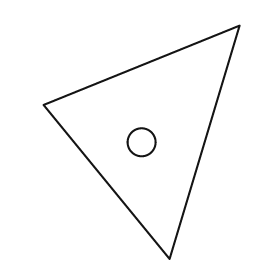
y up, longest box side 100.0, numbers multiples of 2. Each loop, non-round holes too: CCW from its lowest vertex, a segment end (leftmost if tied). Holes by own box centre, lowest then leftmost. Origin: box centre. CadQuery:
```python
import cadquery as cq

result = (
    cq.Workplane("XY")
    .moveTo(12.0, -50.0)
    .lineTo(42.0, 50.0)
    .lineTo(-42.0, 16.0)
    .close()
    .moveTo(0.0, 0.0)
    .circle(6.0)
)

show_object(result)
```